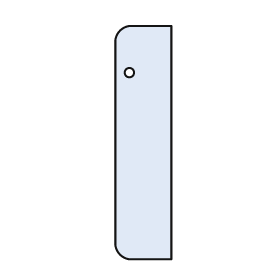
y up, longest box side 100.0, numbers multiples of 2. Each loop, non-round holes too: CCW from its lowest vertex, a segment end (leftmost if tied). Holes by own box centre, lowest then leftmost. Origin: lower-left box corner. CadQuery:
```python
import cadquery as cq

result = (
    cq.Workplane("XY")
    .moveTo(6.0, 0.0)
    .lineTo(24.0, 0.0)
    .lineTo(24.0, 100.0)
    .lineTo(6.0, 100.0)
    .threePointArc((2.0, 98.0), (0.0, 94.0))
    .lineTo(0.0, 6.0)
    .threePointArc((2.0, 2.0), (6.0, 0.0))
    .close()
    .moveTo(6.0, 80.0)
    .circle(2.0)
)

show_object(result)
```